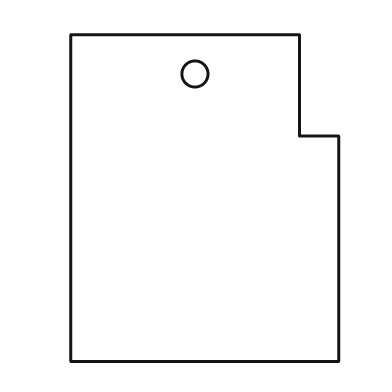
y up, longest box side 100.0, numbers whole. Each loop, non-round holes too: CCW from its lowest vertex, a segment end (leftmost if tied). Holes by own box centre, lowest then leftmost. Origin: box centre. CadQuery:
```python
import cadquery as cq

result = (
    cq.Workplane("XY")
    .moveTo(-41.0, -50.0)
    .lineTo(41.0, -50.0)
    .lineTo(41.0, 19.0)
    .lineTo(29.0, 19.0)
    .lineTo(29.0, 50.0)
    .lineTo(-41.0, 50.0)
    .close()
    .moveTo(-3.0, 38.0)
    .circle(4.0)
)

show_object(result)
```